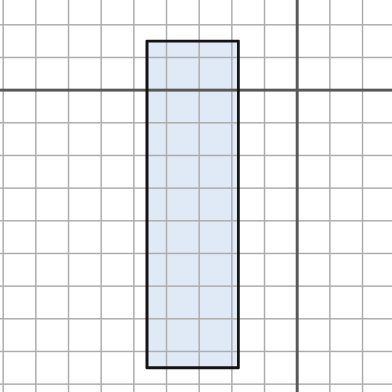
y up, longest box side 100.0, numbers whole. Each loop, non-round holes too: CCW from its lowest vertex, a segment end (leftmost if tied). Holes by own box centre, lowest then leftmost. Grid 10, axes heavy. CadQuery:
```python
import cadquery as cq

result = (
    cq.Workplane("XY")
    .moveTo(-46.0, -85.0)
    .lineTo(-18.0, -85.0)
    .lineTo(-18.0, 15.0)
    .lineTo(-46.0, 15.0)
    .close()
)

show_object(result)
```